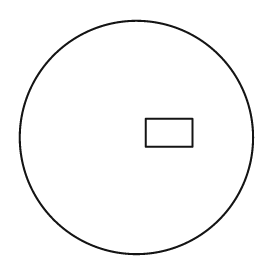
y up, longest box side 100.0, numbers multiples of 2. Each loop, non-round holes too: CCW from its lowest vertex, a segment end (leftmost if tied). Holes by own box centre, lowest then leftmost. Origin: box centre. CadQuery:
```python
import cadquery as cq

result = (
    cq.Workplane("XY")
    .moveTo(0.0, 0.0)
    .circle(50.0)
    .moveTo(4.0, -4.0)
    .lineTo(24.0, -4.0)
    .lineTo(24.0, 8.0)
    .lineTo(4.0, 8.0)
    .close()
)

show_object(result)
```